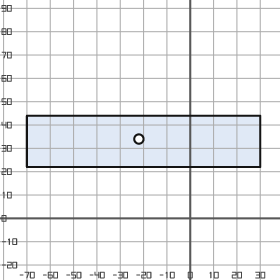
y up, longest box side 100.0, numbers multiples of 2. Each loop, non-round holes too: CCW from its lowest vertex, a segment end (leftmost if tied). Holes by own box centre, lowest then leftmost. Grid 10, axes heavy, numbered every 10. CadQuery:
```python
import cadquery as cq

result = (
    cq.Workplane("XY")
    .moveTo(-70.0, 22.0)
    .lineTo(30.0, 22.0)
    .lineTo(30.0, 44.0)
    .lineTo(-70.0, 44.0)
    .close()
    .moveTo(-22.0, 34.0)
    .circle(2.0)
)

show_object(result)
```